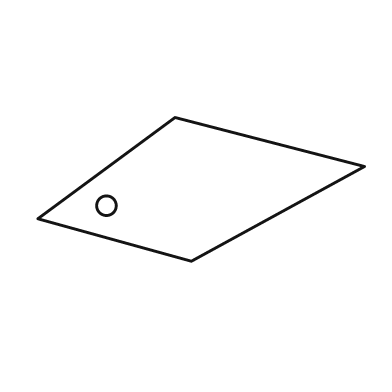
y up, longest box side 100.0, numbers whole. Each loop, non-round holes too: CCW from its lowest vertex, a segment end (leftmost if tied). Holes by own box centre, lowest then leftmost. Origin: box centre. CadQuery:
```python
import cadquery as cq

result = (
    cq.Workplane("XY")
    .moveTo(-3.0, -22.0)
    .lineTo(50.0, 7.0)
    .lineTo(-8.0, 22.0)
    .lineTo(-50.0, -9.0)
    .close()
    .moveTo(-29.0, -5.0)
    .circle(3.0)
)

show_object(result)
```